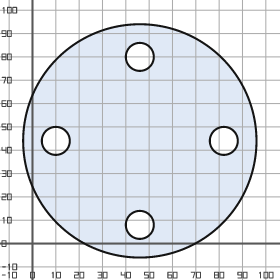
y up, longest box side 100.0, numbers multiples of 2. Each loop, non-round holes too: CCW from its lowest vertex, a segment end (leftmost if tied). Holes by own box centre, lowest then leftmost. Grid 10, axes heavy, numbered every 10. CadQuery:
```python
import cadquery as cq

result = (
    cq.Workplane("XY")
    .moveTo(46.0, 44.0)
    .circle(50.0)
    .moveTo(46.0, 8.0)
    .circle(6.0)
    .moveTo(10.0, 44.0)
    .circle(6.0)
    .moveTo(82.0, 44.0)
    .circle(6.0)
    .moveTo(46.0, 80.0)
    .circle(6.0)
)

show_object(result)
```